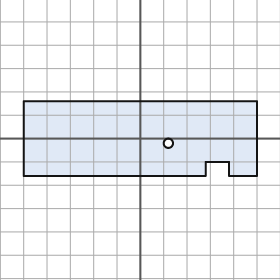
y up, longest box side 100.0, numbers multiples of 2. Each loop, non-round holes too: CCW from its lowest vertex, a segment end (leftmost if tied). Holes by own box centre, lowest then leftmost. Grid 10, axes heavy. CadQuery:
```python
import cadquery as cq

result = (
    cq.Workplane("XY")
    .moveTo(-50.0, -16.0)
    .lineTo(28.0, -16.0)
    .lineTo(28.0, -10.0)
    .lineTo(38.0, -10.0)
    .lineTo(38.0, -16.0)
    .lineTo(50.0, -16.0)
    .lineTo(50.0, 16.0)
    .lineTo(-50.0, 16.0)
    .close()
    .moveTo(12.0, -2.0)
    .circle(2.0)
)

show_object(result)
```